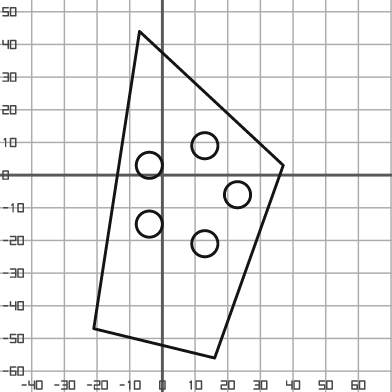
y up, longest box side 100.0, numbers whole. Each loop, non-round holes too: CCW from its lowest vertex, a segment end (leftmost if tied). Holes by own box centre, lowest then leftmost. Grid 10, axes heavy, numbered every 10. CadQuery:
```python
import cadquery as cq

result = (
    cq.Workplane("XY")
    .moveTo(16.0, -56.0)
    .lineTo(37.0, 3.0)
    .lineTo(-7.0, 44.0)
    .lineTo(-21.0, -47.0)
    .close()
    .moveTo(13.0, -21.0)
    .circle(4.0)
    .moveTo(-4.0, -15.0)
    .circle(4.0)
    .moveTo(23.0, -6.0)
    .circle(4.0)
    .moveTo(-4.0, 3.0)
    .circle(4.0)
    .moveTo(13.0, 9.0)
    .circle(4.0)
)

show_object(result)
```